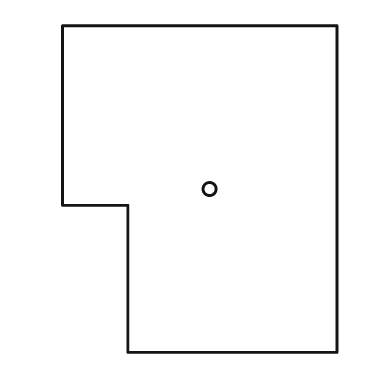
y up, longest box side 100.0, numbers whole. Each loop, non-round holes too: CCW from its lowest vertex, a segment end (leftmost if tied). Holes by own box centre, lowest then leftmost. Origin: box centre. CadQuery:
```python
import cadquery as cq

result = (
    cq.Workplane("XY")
    .moveTo(-22.0, -50.0)
    .lineTo(42.0, -50.0)
    .lineTo(42.0, 50.0)
    .lineTo(-42.0, 50.0)
    .lineTo(-42.0, -5.0)
    .lineTo(-22.0, -5.0)
    .close()
    .moveTo(3.0, 0.0)
    .circle(2.0)
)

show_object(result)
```